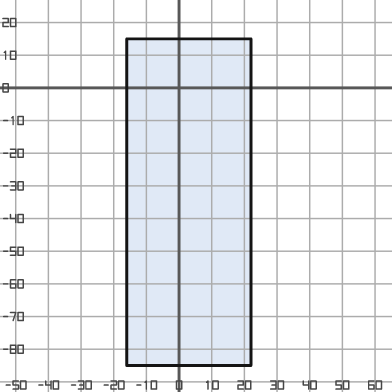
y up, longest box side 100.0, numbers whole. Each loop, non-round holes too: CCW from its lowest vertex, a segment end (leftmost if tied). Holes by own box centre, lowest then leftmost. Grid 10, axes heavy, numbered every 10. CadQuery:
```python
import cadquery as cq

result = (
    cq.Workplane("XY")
    .moveTo(-16.0, -85.0)
    .lineTo(22.0, -85.0)
    .lineTo(22.0, 15.0)
    .lineTo(-16.0, 15.0)
    .close()
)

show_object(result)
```